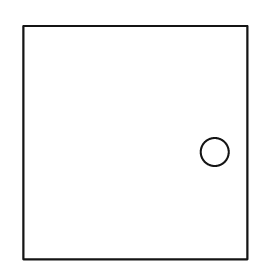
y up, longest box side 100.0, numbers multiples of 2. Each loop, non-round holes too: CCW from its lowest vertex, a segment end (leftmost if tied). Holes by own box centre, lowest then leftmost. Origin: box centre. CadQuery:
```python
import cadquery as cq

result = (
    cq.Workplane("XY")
    .moveTo(-48.0, -50.0)
    .lineTo(48.0, -50.0)
    .lineTo(48.0, 50.0)
    .lineTo(-48.0, 50.0)
    .close()
    .moveTo(34.0, -4.0)
    .circle(6.0)
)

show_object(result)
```